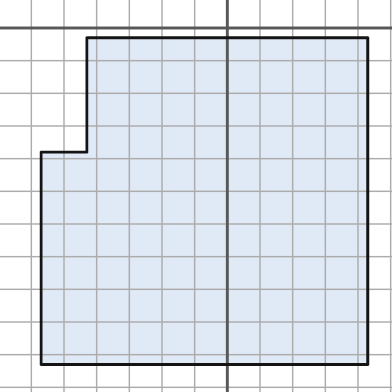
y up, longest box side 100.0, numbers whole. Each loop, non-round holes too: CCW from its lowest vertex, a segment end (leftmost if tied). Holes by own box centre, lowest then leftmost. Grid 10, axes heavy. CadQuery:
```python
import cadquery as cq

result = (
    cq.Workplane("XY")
    .moveTo(-57.0, -103.0)
    .lineTo(43.0, -103.0)
    .lineTo(43.0, -3.0)
    .lineTo(-43.0, -3.0)
    .lineTo(-43.0, -38.0)
    .lineTo(-57.0, -38.0)
    .close()
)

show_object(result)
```